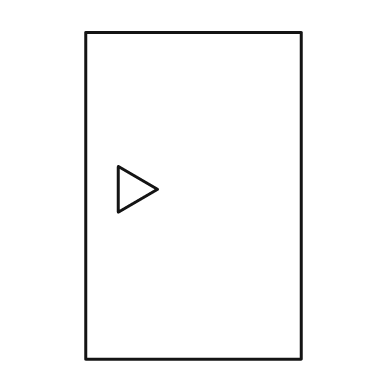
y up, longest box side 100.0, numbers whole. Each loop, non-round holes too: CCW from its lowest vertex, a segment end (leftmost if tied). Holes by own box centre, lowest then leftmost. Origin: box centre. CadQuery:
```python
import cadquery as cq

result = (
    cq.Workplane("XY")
    .moveTo(-33.0, -50.0)
    .lineTo(33.0, -50.0)
    .lineTo(33.0, 50.0)
    .lineTo(-33.0, 50.0)
    .close()
    .moveTo(-23.0, -5.0)
    .lineTo(-11.0, 2.0)
    .lineTo(-23.0, 9.0)
    .close()
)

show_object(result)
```